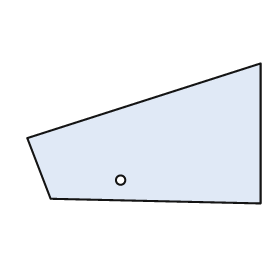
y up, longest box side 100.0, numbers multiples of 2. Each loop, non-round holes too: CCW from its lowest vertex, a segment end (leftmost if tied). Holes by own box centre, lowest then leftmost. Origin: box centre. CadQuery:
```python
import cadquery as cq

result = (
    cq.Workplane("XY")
    .moveTo(50.0, -30.0)
    .lineTo(50.0, 30.0)
    .lineTo(-50.0, -2.0)
    .lineTo(-40.0, -28.0)
    .close()
    .moveTo(-10.0, -20.0)
    .circle(2.0)
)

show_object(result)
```